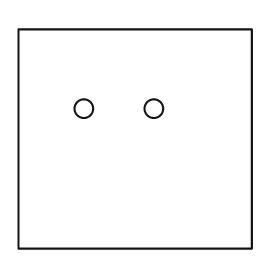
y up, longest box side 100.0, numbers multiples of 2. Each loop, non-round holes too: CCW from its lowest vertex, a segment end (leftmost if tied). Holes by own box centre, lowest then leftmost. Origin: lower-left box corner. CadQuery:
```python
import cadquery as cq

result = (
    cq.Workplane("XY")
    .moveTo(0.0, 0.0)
    .lineTo(100.0, 0.0)
    .lineTo(100.0, 94.0)
    .lineTo(0.0, 94.0)
    .close()
    .moveTo(28.0, 60.0)
    .circle(4.0)
    .moveTo(58.0, 60.0)
    .circle(4.0)
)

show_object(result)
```